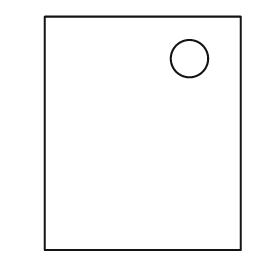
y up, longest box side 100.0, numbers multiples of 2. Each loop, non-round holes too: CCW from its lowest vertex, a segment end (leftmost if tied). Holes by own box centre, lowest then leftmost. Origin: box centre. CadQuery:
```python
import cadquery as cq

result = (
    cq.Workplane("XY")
    .moveTo(-42.0, -50.0)
    .lineTo(42.0, -50.0)
    .lineTo(42.0, 50.0)
    .lineTo(-42.0, 50.0)
    .close()
    .moveTo(20.0, 32.0)
    .circle(8.0)
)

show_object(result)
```